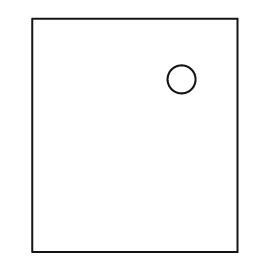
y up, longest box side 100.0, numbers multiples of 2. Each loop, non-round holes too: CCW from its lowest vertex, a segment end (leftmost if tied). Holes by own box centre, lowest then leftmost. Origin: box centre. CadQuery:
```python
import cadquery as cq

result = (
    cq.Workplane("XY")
    .moveTo(-44.0, -50.0)
    .lineTo(44.0, -50.0)
    .lineTo(44.0, 50.0)
    .lineTo(-44.0, 50.0)
    .close()
    .moveTo(20.0, 24.0)
    .circle(6.0)
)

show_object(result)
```